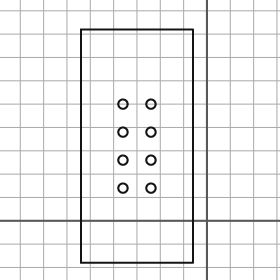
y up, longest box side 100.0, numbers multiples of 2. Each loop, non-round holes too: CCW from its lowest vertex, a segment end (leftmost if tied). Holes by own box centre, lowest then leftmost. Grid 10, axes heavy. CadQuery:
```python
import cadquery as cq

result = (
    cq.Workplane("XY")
    .moveTo(-54.0, -18.0)
    .lineTo(-6.0, -18.0)
    .lineTo(-6.0, 82.0)
    .lineTo(-54.0, 82.0)
    .close()
    .moveTo(-36.0, 14.0)
    .circle(2.0)
    .moveTo(-24.0, 14.0)
    .circle(2.0)
    .moveTo(-36.0, 26.0)
    .circle(2.0)
    .moveTo(-24.0, 26.0)
    .circle(2.0)
    .moveTo(-36.0, 38.0)
    .circle(2.0)
    .moveTo(-24.0, 38.0)
    .circle(2.0)
    .moveTo(-36.0, 50.0)
    .circle(2.0)
    .moveTo(-24.0, 50.0)
    .circle(2.0)
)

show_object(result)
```